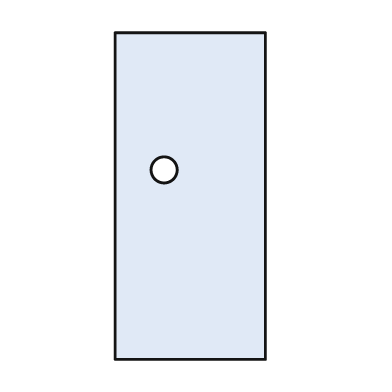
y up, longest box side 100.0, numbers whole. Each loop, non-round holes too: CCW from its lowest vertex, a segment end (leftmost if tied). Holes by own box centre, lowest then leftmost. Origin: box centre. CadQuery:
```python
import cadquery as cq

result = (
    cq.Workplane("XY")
    .moveTo(-23.0, -50.0)
    .lineTo(23.0, -50.0)
    .lineTo(23.0, 50.0)
    .lineTo(-23.0, 50.0)
    .close()
    .moveTo(-8.0, 8.0)
    .circle(4.0)
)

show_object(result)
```